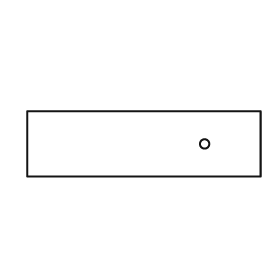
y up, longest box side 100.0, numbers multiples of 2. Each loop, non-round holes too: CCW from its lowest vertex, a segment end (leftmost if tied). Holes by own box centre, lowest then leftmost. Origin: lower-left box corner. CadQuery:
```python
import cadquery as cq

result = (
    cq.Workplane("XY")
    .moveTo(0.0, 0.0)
    .lineTo(100.0, 0.0)
    .lineTo(100.0, 28.0)
    .lineTo(0.0, 28.0)
    .close()
    .moveTo(76.0, 14.0)
    .circle(2.0)
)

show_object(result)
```